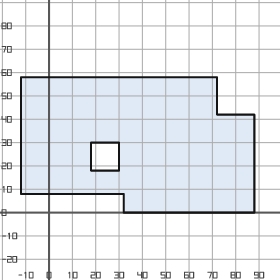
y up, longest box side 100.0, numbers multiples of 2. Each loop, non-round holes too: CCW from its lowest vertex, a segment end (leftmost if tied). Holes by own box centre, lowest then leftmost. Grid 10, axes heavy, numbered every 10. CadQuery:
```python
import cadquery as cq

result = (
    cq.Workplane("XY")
    .moveTo(32.0, 0.0)
    .lineTo(88.0, 0.0)
    .lineTo(88.0, 42.0)
    .lineTo(72.0, 42.0)
    .lineTo(72.0, 58.0)
    .lineTo(-12.0, 58.0)
    .lineTo(-12.0, 8.0)
    .lineTo(32.0, 8.0)
    .close()
    .moveTo(18.0, 18.0)
    .lineTo(30.0, 18.0)
    .lineTo(30.0, 30.0)
    .lineTo(18.0, 30.0)
    .close()
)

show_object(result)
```